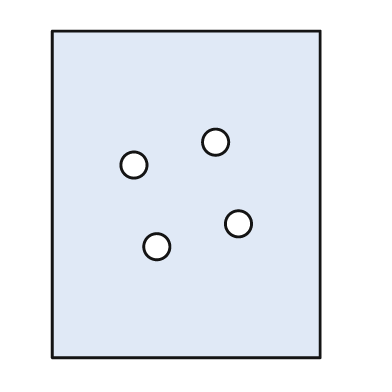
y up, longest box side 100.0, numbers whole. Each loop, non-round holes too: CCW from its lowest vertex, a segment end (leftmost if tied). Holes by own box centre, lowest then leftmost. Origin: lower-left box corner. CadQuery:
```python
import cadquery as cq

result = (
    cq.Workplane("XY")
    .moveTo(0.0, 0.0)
    .lineTo(82.0, 0.0)
    .lineTo(82.0, 100.0)
    .lineTo(0.0, 100.0)
    .close()
    .moveTo(32.0, 34.0)
    .circle(4.0)
    .moveTo(57.0, 41.0)
    .circle(4.0)
    .moveTo(25.0, 59.0)
    .circle(4.0)
    .moveTo(50.0, 66.0)
    .circle(4.0)
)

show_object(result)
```